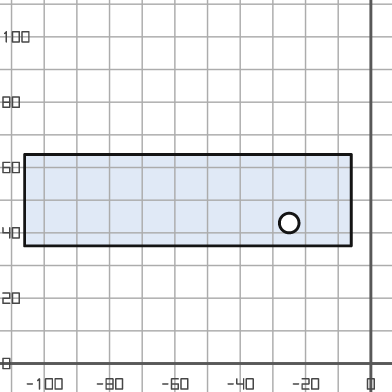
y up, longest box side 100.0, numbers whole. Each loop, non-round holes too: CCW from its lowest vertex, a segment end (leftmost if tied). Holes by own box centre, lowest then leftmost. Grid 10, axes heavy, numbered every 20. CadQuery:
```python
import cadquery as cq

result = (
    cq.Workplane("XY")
    .moveTo(-106.0, 36.0)
    .lineTo(-6.0, 36.0)
    .lineTo(-6.0, 64.0)
    .lineTo(-106.0, 64.0)
    .close()
    .moveTo(-25.0, 43.0)
    .circle(3.0)
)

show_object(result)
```